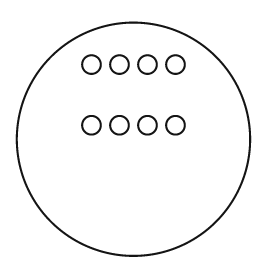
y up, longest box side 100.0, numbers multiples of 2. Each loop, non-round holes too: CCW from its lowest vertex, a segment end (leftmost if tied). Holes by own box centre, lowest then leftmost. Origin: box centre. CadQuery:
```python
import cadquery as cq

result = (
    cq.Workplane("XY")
    .moveTo(0.0, 0.0)
    .circle(50.0)
    .moveTo(-18.0, 6.0)
    .circle(4.0)
    .moveTo(-6.0, 6.0)
    .circle(4.0)
    .moveTo(6.0, 6.0)
    .circle(4.0)
    .moveTo(18.0, 6.0)
    .circle(4.0)
    .moveTo(-18.0, 32.0)
    .circle(4.0)
    .moveTo(-6.0, 32.0)
    .circle(4.0)
    .moveTo(6.0, 32.0)
    .circle(4.0)
    .moveTo(18.0, 32.0)
    .circle(4.0)
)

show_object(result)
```